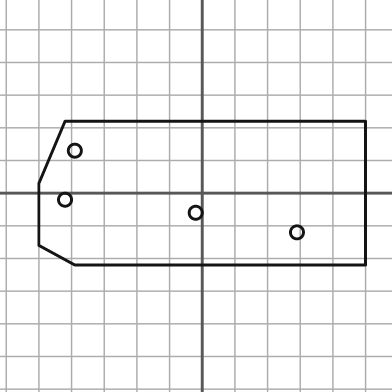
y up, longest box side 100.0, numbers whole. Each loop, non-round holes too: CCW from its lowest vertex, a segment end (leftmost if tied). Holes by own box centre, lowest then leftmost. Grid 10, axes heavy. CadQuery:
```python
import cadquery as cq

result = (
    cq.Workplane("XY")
    .moveTo(-39.0, -22.0)
    .lineTo(50.0, -22.0)
    .lineTo(50.0, 22.0)
    .lineTo(-42.0, 22.0)
    .lineTo(-50.0, 3.0)
    .lineTo(-50.0, -16.0)
    .close()
    .moveTo(29.0, -12.0)
    .circle(2.0)
    .moveTo(-2.0, -6.0)
    .circle(2.0)
    .moveTo(-42.0, -2.0)
    .circle(2.0)
    .moveTo(-39.0, 13.0)
    .circle(2.0)
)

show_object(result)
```